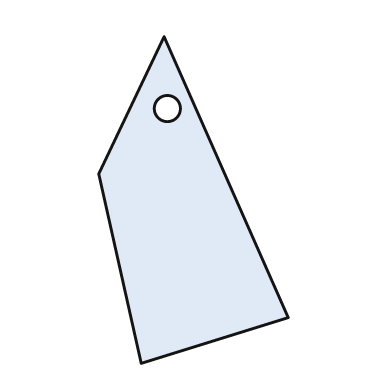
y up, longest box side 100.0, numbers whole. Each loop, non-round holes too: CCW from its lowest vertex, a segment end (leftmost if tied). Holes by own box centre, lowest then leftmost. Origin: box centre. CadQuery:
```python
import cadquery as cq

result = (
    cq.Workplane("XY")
    .moveTo(-16.0, -50.0)
    .lineTo(29.0, -36.0)
    .lineTo(-9.0, 50.0)
    .lineTo(-29.0, 8.0)
    .close()
    .moveTo(-8.0, 28.0)
    .circle(4.0)
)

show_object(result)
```